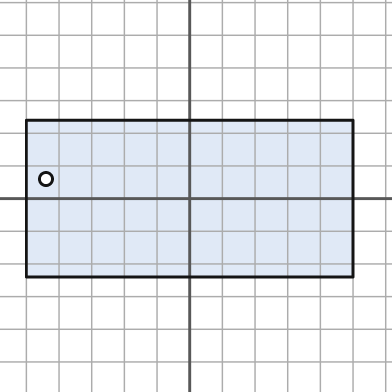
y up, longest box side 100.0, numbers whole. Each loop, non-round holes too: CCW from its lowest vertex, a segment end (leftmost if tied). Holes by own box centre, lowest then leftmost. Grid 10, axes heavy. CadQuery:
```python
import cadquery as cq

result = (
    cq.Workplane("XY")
    .moveTo(-50.0, -24.0)
    .lineTo(50.0, -24.0)
    .lineTo(50.0, 24.0)
    .lineTo(-50.0, 24.0)
    .close()
    .moveTo(-44.0, 6.0)
    .circle(2.0)
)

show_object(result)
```